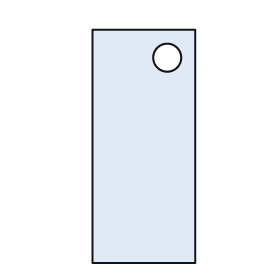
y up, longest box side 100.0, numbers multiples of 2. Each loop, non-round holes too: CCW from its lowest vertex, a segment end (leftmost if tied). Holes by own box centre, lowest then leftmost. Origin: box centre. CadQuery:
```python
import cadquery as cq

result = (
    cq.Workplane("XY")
    .moveTo(-22.0, -50.0)
    .lineTo(22.0, -50.0)
    .lineTo(22.0, 50.0)
    .lineTo(-22.0, 50.0)
    .close()
    .moveTo(10.0, 38.0)
    .circle(6.0)
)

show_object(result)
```